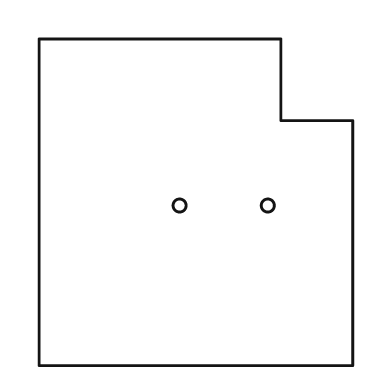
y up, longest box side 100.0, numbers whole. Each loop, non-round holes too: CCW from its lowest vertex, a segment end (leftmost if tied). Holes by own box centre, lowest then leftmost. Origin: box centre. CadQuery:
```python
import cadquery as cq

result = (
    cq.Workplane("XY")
    .moveTo(-48.0, -50.0)
    .lineTo(48.0, -50.0)
    .lineTo(48.0, 25.0)
    .lineTo(26.0, 25.0)
    .lineTo(26.0, 50.0)
    .lineTo(-48.0, 50.0)
    .close()
    .moveTo(-5.0, -1.0)
    .circle(2.0)
    .moveTo(22.0, -1.0)
    .circle(2.0)
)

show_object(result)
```